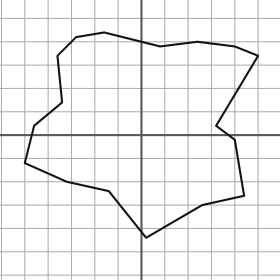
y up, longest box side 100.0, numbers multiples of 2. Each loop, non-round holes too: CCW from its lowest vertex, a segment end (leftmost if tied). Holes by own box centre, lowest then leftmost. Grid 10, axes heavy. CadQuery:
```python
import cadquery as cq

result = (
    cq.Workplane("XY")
    .moveTo(2.0, -44.0)
    .lineTo(26.0, -30.0)
    .lineTo(44.0, -26.0)
    .lineTo(40.0, -2.0)
    .lineTo(32.0, 4.0)
    .lineTo(50.0, 34.0)
    .lineTo(40.0, 38.0)
    .lineTo(24.0, 40.0)
    .lineTo(8.0, 38.0)
    .lineTo(-16.0, 44.0)
    .lineTo(-28.0, 42.0)
    .lineTo(-36.0, 34.0)
    .lineTo(-34.0, 14.0)
    .lineTo(-46.0, 4.0)
    .lineTo(-50.0, -12.0)
    .lineTo(-32.0, -20.0)
    .lineTo(-14.0, -24.0)
    .close()
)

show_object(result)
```